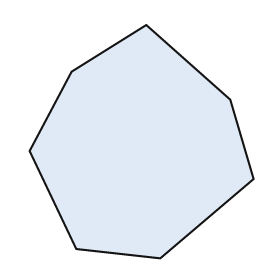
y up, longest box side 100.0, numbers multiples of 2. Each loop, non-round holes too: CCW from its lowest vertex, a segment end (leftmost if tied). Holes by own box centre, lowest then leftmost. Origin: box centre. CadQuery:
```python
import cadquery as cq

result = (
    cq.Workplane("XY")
    .moveTo(8.0, -50.0)
    .lineTo(48.0, -16.0)
    .lineTo(38.0, 18.0)
    .lineTo(2.0, 50.0)
    .lineTo(-30.0, 30.0)
    .lineTo(-48.0, -4.0)
    .lineTo(-28.0, -46.0)
    .close()
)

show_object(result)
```